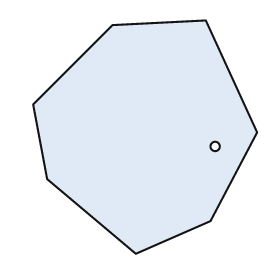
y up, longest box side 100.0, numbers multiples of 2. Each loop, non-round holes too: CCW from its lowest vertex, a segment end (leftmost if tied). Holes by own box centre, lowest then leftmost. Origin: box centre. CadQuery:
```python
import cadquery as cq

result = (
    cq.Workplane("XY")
    .moveTo(-4.0, -50.0)
    .lineTo(28.0, -36.0)
    .lineTo(48.0, 2.0)
    .lineTo(26.0, 50.0)
    .lineTo(-14.0, 48.0)
    .lineTo(-48.0, 14.0)
    .lineTo(-42.0, -18.0)
    .close()
    .moveTo(30.0, -4.0)
    .circle(2.0)
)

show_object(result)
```